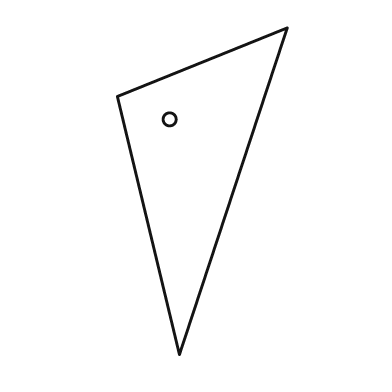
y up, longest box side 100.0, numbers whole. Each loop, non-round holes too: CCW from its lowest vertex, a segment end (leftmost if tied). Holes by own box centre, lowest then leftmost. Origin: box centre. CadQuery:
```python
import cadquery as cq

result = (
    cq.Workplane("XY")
    .moveTo(-7.0, -50.0)
    .lineTo(26.0, 50.0)
    .lineTo(-26.0, 29.0)
    .close()
    .moveTo(-10.0, 22.0)
    .circle(2.0)
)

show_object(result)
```